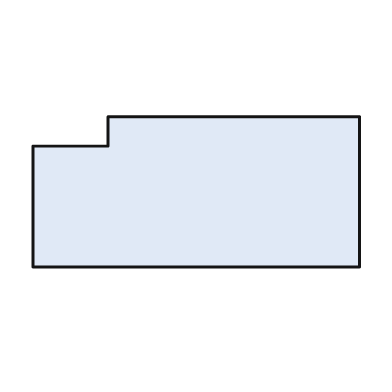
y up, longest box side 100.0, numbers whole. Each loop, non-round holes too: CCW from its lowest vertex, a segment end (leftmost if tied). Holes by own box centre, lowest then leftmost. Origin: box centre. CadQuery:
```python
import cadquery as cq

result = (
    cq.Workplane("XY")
    .moveTo(-50.0, -23.0)
    .lineTo(50.0, -23.0)
    .lineTo(50.0, 23.0)
    .lineTo(-27.0, 23.0)
    .lineTo(-27.0, 14.0)
    .lineTo(-50.0, 14.0)
    .close()
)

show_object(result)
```